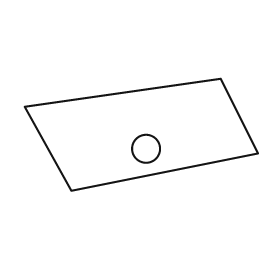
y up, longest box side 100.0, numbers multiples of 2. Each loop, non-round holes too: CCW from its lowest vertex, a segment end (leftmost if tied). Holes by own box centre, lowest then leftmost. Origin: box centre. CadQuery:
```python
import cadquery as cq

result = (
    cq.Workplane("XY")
    .moveTo(-30.0, -24.0)
    .lineTo(50.0, -8.0)
    .lineTo(34.0, 24.0)
    .lineTo(-50.0, 12.0)
    .close()
    .moveTo(2.0, -6.0)
    .circle(6.0)
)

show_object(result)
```